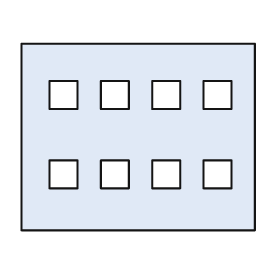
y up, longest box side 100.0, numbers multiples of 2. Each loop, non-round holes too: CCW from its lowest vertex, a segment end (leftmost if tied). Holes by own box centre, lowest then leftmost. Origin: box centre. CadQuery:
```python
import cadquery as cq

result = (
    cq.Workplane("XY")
    .moveTo(-50.0, -40.0)
    .lineTo(50.0, -40.0)
    .lineTo(50.0, 40.0)
    .lineTo(-50.0, 40.0)
    .close()
    .moveTo(-38.0, -22.0)
    .lineTo(-26.0, -22.0)
    .lineTo(-26.0, -10.0)
    .lineTo(-38.0, -10.0)
    .close()
    .moveTo(-16.0, -22.0)
    .lineTo(-4.0, -22.0)
    .lineTo(-4.0, -10.0)
    .lineTo(-16.0, -10.0)
    .close()
    .moveTo(6.0, -22.0)
    .lineTo(18.0, -22.0)
    .lineTo(18.0, -10.0)
    .lineTo(6.0, -10.0)
    .close()
    .moveTo(28.0, -22.0)
    .lineTo(40.0, -22.0)
    .lineTo(40.0, -10.0)
    .lineTo(28.0, -10.0)
    .close()
    .moveTo(-38.0, 12.0)
    .lineTo(-26.0, 12.0)
    .lineTo(-26.0, 24.0)
    .lineTo(-38.0, 24.0)
    .close()
    .moveTo(-16.0, 12.0)
    .lineTo(-4.0, 12.0)
    .lineTo(-4.0, 24.0)
    .lineTo(-16.0, 24.0)
    .close()
    .moveTo(6.0, 12.0)
    .lineTo(18.0, 12.0)
    .lineTo(18.0, 24.0)
    .lineTo(6.0, 24.0)
    .close()
    .moveTo(28.0, 12.0)
    .lineTo(40.0, 12.0)
    .lineTo(40.0, 24.0)
    .lineTo(28.0, 24.0)
    .close()
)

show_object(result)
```